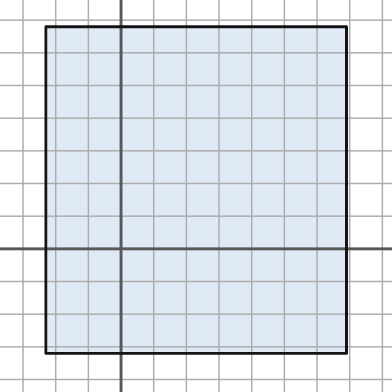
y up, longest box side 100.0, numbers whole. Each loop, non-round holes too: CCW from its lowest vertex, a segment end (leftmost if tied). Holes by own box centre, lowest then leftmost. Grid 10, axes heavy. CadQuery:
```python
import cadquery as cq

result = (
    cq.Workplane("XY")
    .moveTo(-23.0, -32.0)
    .lineTo(69.0, -32.0)
    .lineTo(69.0, 68.0)
    .lineTo(-23.0, 68.0)
    .close()
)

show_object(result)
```